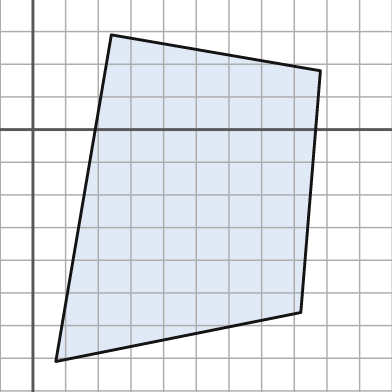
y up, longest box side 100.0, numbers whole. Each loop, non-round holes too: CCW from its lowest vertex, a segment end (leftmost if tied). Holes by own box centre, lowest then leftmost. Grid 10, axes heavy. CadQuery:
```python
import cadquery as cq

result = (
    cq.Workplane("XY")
    .moveTo(7.0, -71.0)
    .lineTo(82.0, -56.0)
    .lineTo(88.0, 18.0)
    .lineTo(24.0, 29.0)
    .close()
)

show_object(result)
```